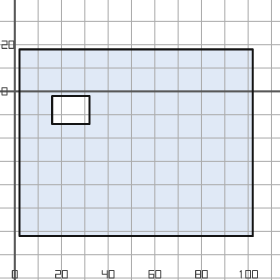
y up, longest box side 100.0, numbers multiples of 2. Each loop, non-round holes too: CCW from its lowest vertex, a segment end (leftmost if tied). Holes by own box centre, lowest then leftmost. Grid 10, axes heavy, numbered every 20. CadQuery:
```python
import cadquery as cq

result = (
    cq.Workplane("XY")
    .moveTo(2.0, -62.0)
    .lineTo(102.0, -62.0)
    .lineTo(102.0, 18.0)
    .lineTo(2.0, 18.0)
    .close()
    .moveTo(16.0, -14.0)
    .lineTo(32.0, -14.0)
    .lineTo(32.0, -2.0)
    .lineTo(16.0, -2.0)
    .close()
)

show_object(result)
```